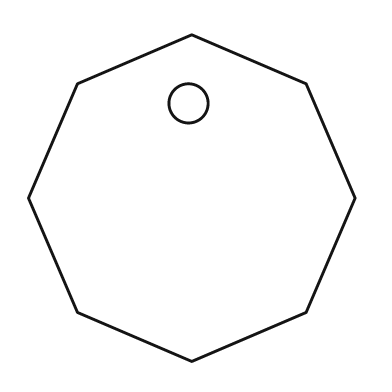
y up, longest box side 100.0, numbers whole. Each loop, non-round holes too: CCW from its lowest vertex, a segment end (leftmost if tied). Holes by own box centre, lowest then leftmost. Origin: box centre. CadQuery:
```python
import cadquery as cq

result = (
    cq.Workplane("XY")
    .moveTo(0.0, -50.0)
    .lineTo(35.0, -35.0)
    .lineTo(50.0, 0.0)
    .lineTo(35.0, 35.0)
    .lineTo(0.0, 50.0)
    .lineTo(-35.0, 35.0)
    .lineTo(-50.0, 0.0)
    .lineTo(-35.0, -35.0)
    .close()
    .moveTo(-1.0, 29.0)
    .circle(6.0)
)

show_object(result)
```